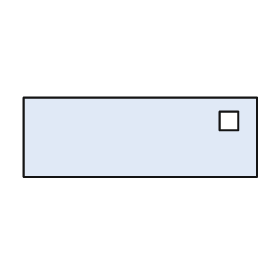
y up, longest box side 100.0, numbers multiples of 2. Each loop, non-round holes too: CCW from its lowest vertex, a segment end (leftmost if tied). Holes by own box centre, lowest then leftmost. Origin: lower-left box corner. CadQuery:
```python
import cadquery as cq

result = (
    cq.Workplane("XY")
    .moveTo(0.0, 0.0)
    .lineTo(100.0, 0.0)
    .lineTo(100.0, 34.0)
    .lineTo(0.0, 34.0)
    .close()
    .moveTo(84.0, 20.0)
    .lineTo(92.0, 20.0)
    .lineTo(92.0, 28.0)
    .lineTo(84.0, 28.0)
    .close()
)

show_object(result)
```